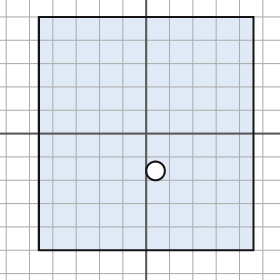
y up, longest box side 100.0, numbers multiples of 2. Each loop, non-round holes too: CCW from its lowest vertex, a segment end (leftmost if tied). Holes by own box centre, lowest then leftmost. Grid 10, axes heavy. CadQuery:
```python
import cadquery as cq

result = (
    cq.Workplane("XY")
    .moveTo(-46.0, -50.0)
    .lineTo(46.0, -50.0)
    .lineTo(46.0, 50.0)
    .lineTo(-46.0, 50.0)
    .close()
    .moveTo(4.0, -16.0)
    .circle(4.0)
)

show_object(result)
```